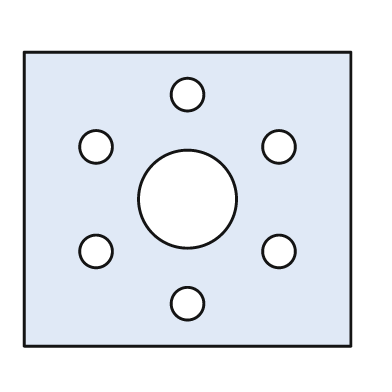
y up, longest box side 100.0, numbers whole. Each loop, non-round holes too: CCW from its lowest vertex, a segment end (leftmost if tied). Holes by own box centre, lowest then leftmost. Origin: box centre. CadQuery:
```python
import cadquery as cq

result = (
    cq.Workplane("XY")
    .moveTo(-50.0, -45.0)
    .lineTo(50.0, -45.0)
    .lineTo(50.0, 45.0)
    .lineTo(-50.0, 45.0)
    .close()
    .moveTo(0.0, -32.0)
    .circle(5.0)
    .moveTo(-28.0, -16.0)
    .circle(5.0)
    .moveTo(28.0, -16.0)
    .circle(5.0)
    .moveTo(0.0, 0.0)
    .circle(15.0)
    .moveTo(-28.0, 16.0)
    .circle(5.0)
    .moveTo(28.0, 16.0)
    .circle(5.0)
    .moveTo(0.0, 32.0)
    .circle(5.0)
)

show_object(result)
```